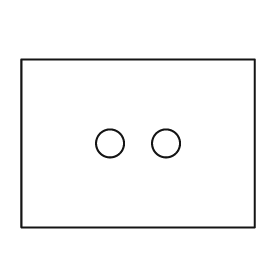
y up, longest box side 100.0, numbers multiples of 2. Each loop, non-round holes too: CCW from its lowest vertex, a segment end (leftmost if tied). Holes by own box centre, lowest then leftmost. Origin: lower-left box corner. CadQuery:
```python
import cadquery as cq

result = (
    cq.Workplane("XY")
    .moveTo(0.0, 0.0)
    .lineTo(100.0, 0.0)
    .lineTo(100.0, 72.0)
    .lineTo(0.0, 72.0)
    .close()
    .moveTo(38.0, 36.0)
    .circle(6.0)
    .moveTo(62.0, 36.0)
    .circle(6.0)
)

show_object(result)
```